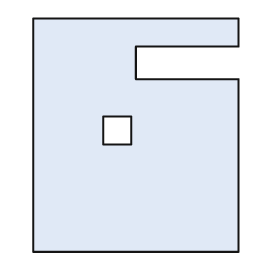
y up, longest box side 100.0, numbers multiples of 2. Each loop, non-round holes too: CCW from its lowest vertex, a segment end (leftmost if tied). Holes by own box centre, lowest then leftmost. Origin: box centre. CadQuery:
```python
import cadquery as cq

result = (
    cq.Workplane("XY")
    .moveTo(-44.0, -50.0)
    .lineTo(44.0, -50.0)
    .lineTo(44.0, 24.0)
    .lineTo(0.0, 24.0)
    .lineTo(0.0, 38.0)
    .lineTo(44.0, 38.0)
    .lineTo(44.0, 50.0)
    .lineTo(-44.0, 50.0)
    .close()
    .moveTo(-14.0, -4.0)
    .lineTo(-2.0, -4.0)
    .lineTo(-2.0, 8.0)
    .lineTo(-14.0, 8.0)
    .close()
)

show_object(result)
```